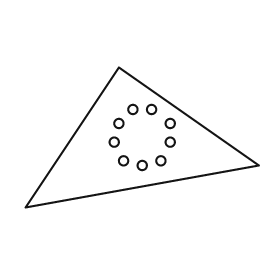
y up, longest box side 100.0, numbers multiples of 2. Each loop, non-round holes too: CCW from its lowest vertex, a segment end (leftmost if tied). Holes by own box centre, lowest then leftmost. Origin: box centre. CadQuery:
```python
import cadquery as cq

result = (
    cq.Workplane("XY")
    .moveTo(-50.0, -30.0)
    .lineTo(50.0, -12.0)
    .lineTo(-10.0, 30.0)
    .close()
    .moveTo(0.0, -12.0)
    .circle(2.0)
    .moveTo(-8.0, -10.0)
    .circle(2.0)
    .moveTo(8.0, -10.0)
    .circle(2.0)
    .moveTo(-12.0, -2.0)
    .circle(2.0)
    .moveTo(12.0, -2.0)
    .circle(2.0)
    .moveTo(-10.0, 6.0)
    .circle(2.0)
    .moveTo(12.0, 6.0)
    .circle(2.0)
    .moveTo(-4.0, 12.0)
    .circle(2.0)
    .moveTo(4.0, 12.0)
    .circle(2.0)
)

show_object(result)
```